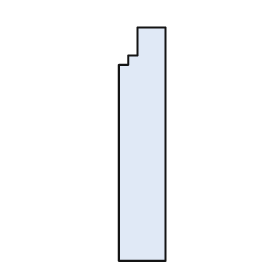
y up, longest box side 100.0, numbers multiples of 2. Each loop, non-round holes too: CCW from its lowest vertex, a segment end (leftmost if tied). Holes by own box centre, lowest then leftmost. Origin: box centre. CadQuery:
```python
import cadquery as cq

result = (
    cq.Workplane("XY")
    .moveTo(-10.0, -50.0)
    .lineTo(10.0, -50.0)
    .lineTo(10.0, 50.0)
    .lineTo(-2.0, 50.0)
    .lineTo(-2.0, 38.0)
    .lineTo(-6.0, 38.0)
    .lineTo(-6.0, 34.0)
    .lineTo(-10.0, 34.0)
    .close()
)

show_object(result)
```